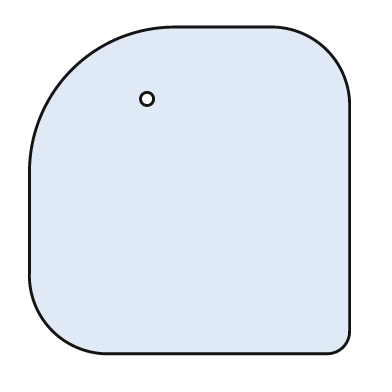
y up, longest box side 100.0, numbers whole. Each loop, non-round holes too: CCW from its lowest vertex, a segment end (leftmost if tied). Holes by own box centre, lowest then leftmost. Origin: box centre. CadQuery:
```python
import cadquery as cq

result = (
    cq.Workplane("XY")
    .moveTo(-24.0, -50.0)
    .lineTo(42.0, -50.0)
    .threePointArc((47.0, -48.0), (49.0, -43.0))
    .lineTo(49.0, 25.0)
    .threePointArc((42.0, 43.0), (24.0, 50.0))
    .lineTo(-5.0, 50.0)
    .threePointArc((-36.0, 37.0), (-49.0, 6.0))
    .lineTo(-49.0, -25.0)
    .threePointArc((-42.0, -43.0), (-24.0, -50.0))
    .close()
    .moveTo(-13.0, 28.0)
    .circle(2.0)
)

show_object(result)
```